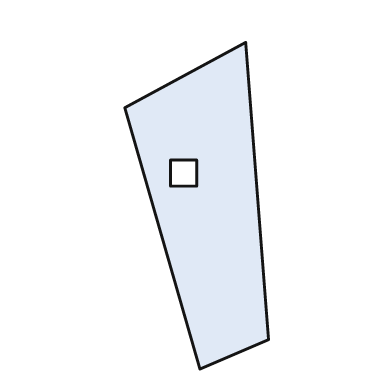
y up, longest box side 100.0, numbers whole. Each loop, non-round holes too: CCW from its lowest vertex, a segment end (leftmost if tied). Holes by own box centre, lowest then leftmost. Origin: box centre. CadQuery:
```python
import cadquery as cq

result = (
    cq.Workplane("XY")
    .moveTo(1.0, -50.0)
    .lineTo(22.0, -41.0)
    .lineTo(15.0, 50.0)
    .lineTo(-22.0, 30.0)
    .close()
    .moveTo(-8.0, 6.0)
    .lineTo(0.0, 6.0)
    .lineTo(0.0, 14.0)
    .lineTo(-8.0, 14.0)
    .close()
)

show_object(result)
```